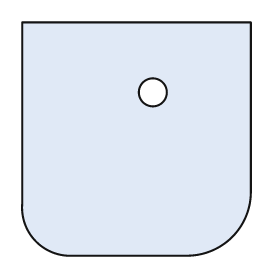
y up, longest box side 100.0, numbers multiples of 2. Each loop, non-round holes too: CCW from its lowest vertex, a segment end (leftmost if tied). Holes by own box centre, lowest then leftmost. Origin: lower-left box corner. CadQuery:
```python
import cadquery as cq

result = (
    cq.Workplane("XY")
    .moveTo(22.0, 0.0)
    .lineTo(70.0, 0.0)
    .threePointArc((90.0, 8.0), (98.0, 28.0))
    .lineTo(98.0, 100.0)
    .lineTo(0.0, 100.0)
    .lineTo(0.0, 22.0)
    .threePointArc((6.0, 6.0), (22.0, 0.0))
    .close()
    .moveTo(56.0, 70.0)
    .circle(6.0)
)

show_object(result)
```